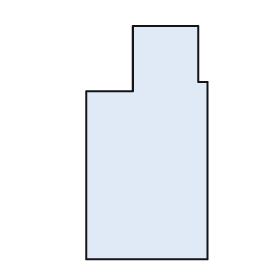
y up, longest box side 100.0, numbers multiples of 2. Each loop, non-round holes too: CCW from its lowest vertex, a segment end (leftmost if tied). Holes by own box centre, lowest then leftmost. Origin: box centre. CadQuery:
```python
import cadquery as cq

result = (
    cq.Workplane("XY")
    .moveTo(-26.0, -50.0)
    .lineTo(26.0, -50.0)
    .lineTo(26.0, 26.0)
    .lineTo(22.0, 26.0)
    .lineTo(22.0, 50.0)
    .lineTo(-6.0, 50.0)
    .lineTo(-6.0, 22.0)
    .lineTo(-26.0, 22.0)
    .close()
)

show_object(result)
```